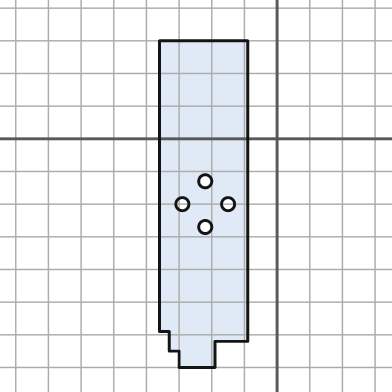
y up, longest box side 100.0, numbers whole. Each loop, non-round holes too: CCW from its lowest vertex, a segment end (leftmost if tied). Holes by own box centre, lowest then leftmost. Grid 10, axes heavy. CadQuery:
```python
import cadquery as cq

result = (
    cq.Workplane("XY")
    .moveTo(-30.0, -70.0)
    .lineTo(-19.0, -70.0)
    .lineTo(-19.0, -62.0)
    .lineTo(-9.0, -62.0)
    .lineTo(-9.0, 30.0)
    .lineTo(-36.0, 30.0)
    .lineTo(-36.0, -59.0)
    .lineTo(-33.0, -59.0)
    .lineTo(-33.0, -65.0)
    .lineTo(-30.0, -65.0)
    .close()
    .moveTo(-22.0, -27.0)
    .circle(2.0)
    .moveTo(-29.0, -20.0)
    .circle(2.0)
    .moveTo(-15.0, -20.0)
    .circle(2.0)
    .moveTo(-22.0, -13.0)
    .circle(2.0)
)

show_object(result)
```